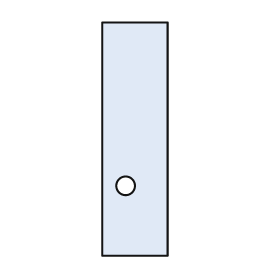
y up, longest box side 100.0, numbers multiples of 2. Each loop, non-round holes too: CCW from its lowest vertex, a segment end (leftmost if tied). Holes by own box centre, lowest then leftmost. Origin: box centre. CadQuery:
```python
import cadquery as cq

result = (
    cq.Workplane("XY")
    .moveTo(-14.0, -50.0)
    .lineTo(14.0, -50.0)
    .lineTo(14.0, 50.0)
    .lineTo(-14.0, 50.0)
    .close()
    .moveTo(-4.0, -20.0)
    .circle(4.0)
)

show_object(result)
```